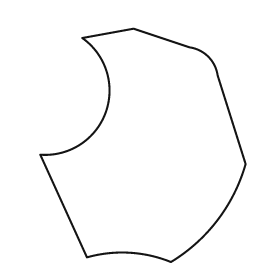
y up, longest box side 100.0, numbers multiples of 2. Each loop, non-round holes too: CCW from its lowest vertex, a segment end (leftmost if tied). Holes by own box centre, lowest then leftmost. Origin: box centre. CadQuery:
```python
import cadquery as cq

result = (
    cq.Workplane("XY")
    .moveTo(12.0, -50.0)
    .threePointArc((32.0, -32.0), (44.0, -8.0))
    .lineTo(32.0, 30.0)
    .threePointArc((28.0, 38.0), (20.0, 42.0))
    .lineTo(-4.0, 50.0)
    .lineTo(-26.0, 46.0)
    .threePointArc((-16.0, 14.0), (-44.0, -4.0))
    .lineTo(-24.0, -48.0)
    .threePointArc((-6.0, -46.0), (12.0, -50.0))
    .close()
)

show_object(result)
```